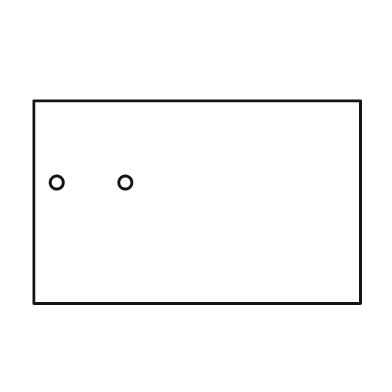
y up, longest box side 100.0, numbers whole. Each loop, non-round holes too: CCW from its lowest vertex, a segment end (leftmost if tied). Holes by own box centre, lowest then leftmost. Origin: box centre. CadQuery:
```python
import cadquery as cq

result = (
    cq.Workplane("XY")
    .moveTo(-50.0, -31.0)
    .lineTo(50.0, -31.0)
    .lineTo(50.0, 31.0)
    .lineTo(-50.0, 31.0)
    .close()
    .moveTo(-43.0, 6.0)
    .circle(2.0)
    .moveTo(-22.0, 6.0)
    .circle(2.0)
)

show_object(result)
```